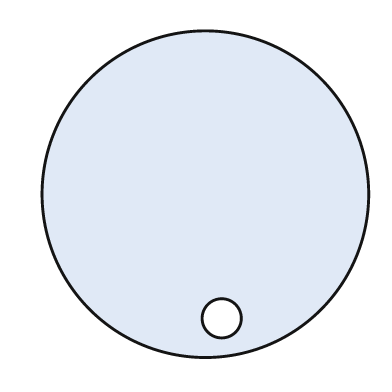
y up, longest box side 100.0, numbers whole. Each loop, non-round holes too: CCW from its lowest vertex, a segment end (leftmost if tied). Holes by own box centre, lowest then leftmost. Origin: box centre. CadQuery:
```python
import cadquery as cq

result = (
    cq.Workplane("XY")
    .moveTo(0.0, 0.0)
    .circle(50.0)
    .moveTo(5.0, -38.0)
    .circle(6.0)
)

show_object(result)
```